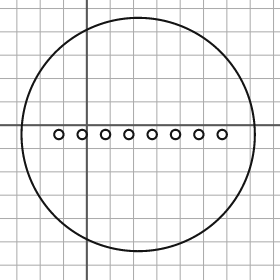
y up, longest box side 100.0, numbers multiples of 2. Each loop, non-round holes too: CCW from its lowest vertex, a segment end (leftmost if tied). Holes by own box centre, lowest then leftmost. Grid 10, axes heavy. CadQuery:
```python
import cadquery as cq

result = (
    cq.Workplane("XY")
    .moveTo(22.0, -4.0)
    .circle(50.0)
    .moveTo(-12.0, -4.0)
    .circle(2.0)
    .moveTo(-2.0, -4.0)
    .circle(2.0)
    .moveTo(8.0, -4.0)
    .circle(2.0)
    .moveTo(18.0, -4.0)
    .circle(2.0)
    .moveTo(28.0, -4.0)
    .circle(2.0)
    .moveTo(38.0, -4.0)
    .circle(2.0)
    .moveTo(48.0, -4.0)
    .circle(2.0)
    .moveTo(58.0, -4.0)
    .circle(2.0)
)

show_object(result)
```